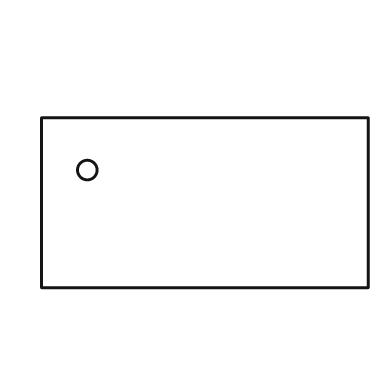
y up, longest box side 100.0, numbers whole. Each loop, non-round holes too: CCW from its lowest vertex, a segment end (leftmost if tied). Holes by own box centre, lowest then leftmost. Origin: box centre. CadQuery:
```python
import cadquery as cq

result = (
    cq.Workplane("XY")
    .moveTo(-50.0, -26.0)
    .lineTo(50.0, -26.0)
    .lineTo(50.0, 26.0)
    .lineTo(-50.0, 26.0)
    .close()
    .moveTo(-36.0, 10.0)
    .circle(3.0)
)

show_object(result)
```